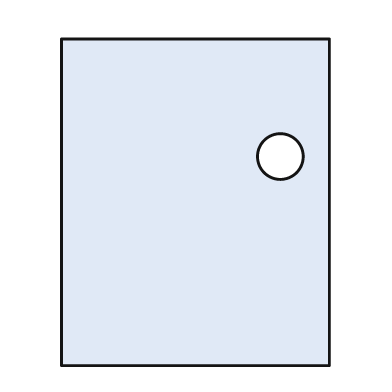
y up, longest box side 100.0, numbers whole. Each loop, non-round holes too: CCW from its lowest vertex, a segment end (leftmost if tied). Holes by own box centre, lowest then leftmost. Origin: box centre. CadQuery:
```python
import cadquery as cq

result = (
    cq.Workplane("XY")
    .moveTo(-41.0, -50.0)
    .lineTo(41.0, -50.0)
    .lineTo(41.0, 50.0)
    .lineTo(-41.0, 50.0)
    .close()
    .moveTo(26.0, 14.0)
    .circle(7.0)
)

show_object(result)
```